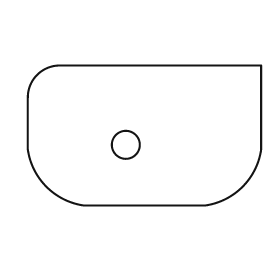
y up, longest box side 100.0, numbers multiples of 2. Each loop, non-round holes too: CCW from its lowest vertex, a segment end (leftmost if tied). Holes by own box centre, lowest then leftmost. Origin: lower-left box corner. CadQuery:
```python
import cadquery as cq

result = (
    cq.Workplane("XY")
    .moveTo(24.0, 0.0)
    .lineTo(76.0, 0.0)
    .threePointArc((92.0, 8.0), (100.0, 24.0))
    .lineTo(100.0, 60.0)
    .lineTo(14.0, 60.0)
    .threePointArc((4.0, 56.0), (0.0, 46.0))
    .lineTo(0.0, 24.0)
    .threePointArc((8.0, 8.0), (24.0, 0.0))
    .close()
    .moveTo(42.0, 26.0)
    .circle(6.0)
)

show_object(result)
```